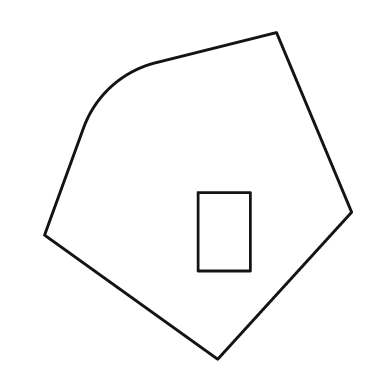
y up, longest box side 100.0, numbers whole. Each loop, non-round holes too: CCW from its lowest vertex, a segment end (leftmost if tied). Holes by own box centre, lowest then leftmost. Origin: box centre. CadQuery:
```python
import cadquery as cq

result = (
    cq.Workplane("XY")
    .moveTo(6.0, -50.0)
    .lineTo(47.0, -5.0)
    .lineTo(24.0, 50.0)
    .lineTo(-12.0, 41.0)
    .threePointArc((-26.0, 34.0), (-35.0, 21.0))
    .lineTo(-47.0, -12.0)
    .close()
    .moveTo(0.0, -23.0)
    .lineTo(16.0, -23.0)
    .lineTo(16.0, 1.0)
    .lineTo(0.0, 1.0)
    .close()
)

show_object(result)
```